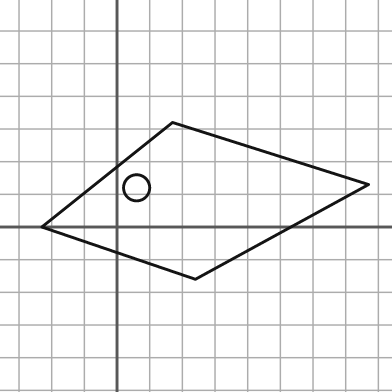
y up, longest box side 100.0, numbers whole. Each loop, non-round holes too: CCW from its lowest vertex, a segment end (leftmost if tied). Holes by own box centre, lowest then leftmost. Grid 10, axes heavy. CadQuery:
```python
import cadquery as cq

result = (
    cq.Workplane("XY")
    .moveTo(24.0, -16.0)
    .lineTo(77.0, 13.0)
    .lineTo(17.0, 32.0)
    .lineTo(-23.0, 0.0)
    .close()
    .moveTo(6.0, 12.0)
    .circle(4.0)
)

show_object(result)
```